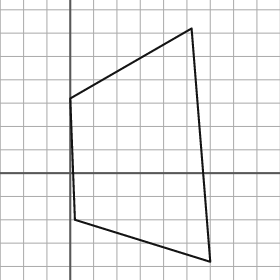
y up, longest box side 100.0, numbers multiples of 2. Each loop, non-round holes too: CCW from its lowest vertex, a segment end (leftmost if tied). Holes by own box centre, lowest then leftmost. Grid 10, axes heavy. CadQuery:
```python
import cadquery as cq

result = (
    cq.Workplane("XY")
    .moveTo(60.0, -38.0)
    .lineTo(52.0, 62.0)
    .lineTo(0.0, 32.0)
    .lineTo(2.0, -20.0)
    .close()
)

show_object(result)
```